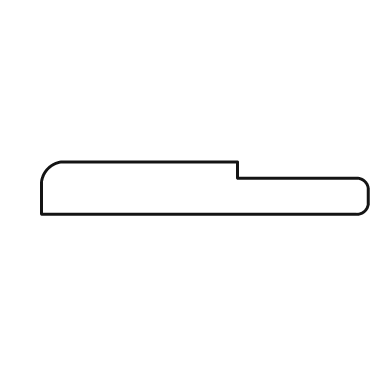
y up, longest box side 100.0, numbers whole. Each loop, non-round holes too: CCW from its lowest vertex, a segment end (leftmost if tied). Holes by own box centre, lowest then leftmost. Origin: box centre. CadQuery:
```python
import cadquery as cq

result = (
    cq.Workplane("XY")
    .moveTo(-50.0, -8.0)
    .lineTo(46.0, -8.0)
    .threePointArc((49.0, -7.0), (50.0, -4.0))
    .lineTo(50.0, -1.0)
    .threePointArc((49.0, 2.0), (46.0, 3.0))
    .lineTo(10.0, 3.0)
    .lineTo(10.0, 8.0)
    .lineTo(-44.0, 8.0)
    .threePointArc((-48.0, 6.0), (-50.0, 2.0))
    .close()
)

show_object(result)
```